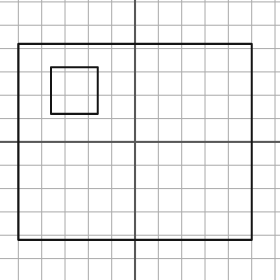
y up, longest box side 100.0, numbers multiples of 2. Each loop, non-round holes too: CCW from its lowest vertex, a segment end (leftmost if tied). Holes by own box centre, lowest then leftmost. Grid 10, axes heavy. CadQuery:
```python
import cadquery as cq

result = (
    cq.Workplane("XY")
    .moveTo(-50.0, -42.0)
    .lineTo(50.0, -42.0)
    .lineTo(50.0, 42.0)
    .lineTo(-50.0, 42.0)
    .close()
    .moveTo(-36.0, 12.0)
    .lineTo(-16.0, 12.0)
    .lineTo(-16.0, 32.0)
    .lineTo(-36.0, 32.0)
    .close()
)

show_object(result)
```